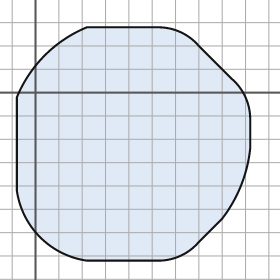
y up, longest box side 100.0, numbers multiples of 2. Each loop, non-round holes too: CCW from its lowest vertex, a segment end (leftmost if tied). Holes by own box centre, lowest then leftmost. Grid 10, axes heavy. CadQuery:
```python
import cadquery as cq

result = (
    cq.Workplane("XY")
    .moveTo(22.0, -72.0)
    .lineTo(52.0, -72.0)
    .threePointArc((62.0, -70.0), (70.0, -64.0))
    .lineTo(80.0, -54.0)
    .threePointArc((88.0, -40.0), (92.0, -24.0))
    .lineTo(92.0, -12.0)
    .threePointArc((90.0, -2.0), (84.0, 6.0))
    .lineTo(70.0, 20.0)
    .threePointArc((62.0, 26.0), (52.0, 28.0))
    .lineTo(22.0, 28.0)
    .threePointArc((4.0, 16.0), (-8.0, -2.0))
    .lineTo(-8.0, -42.0)
    .threePointArc((2.0, -62.0), (22.0, -72.0))
    .close()
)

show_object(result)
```